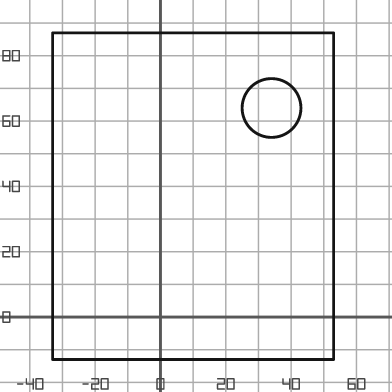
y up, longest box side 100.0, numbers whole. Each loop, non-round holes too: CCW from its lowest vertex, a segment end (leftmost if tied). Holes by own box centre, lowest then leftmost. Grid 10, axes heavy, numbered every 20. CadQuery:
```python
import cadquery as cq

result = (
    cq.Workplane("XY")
    .moveTo(-33.0, -13.0)
    .lineTo(53.0, -13.0)
    .lineTo(53.0, 87.0)
    .lineTo(-33.0, 87.0)
    .close()
    .moveTo(34.0, 64.0)
    .circle(9.0)
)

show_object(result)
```